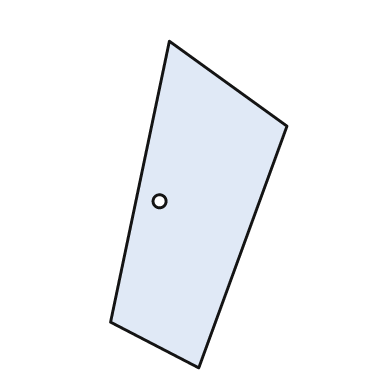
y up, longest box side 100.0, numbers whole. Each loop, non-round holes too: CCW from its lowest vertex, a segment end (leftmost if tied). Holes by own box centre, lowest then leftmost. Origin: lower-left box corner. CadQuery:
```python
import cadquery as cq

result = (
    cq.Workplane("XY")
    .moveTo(27.0, 0.0)
    .lineTo(54.0, 74.0)
    .lineTo(18.0, 100.0)
    .lineTo(0.0, 14.0)
    .close()
    .moveTo(15.0, 51.0)
    .circle(2.0)
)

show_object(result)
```